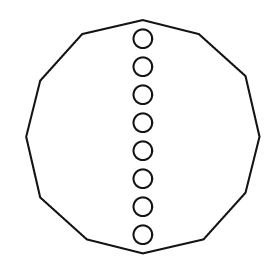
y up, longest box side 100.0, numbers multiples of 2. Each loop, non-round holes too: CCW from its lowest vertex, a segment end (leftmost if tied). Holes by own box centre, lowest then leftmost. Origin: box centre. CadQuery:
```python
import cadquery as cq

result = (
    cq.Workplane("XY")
    .moveTo(0.0, -50.0)
    .lineTo(26.0, -44.0)
    .lineTo(44.0, -24.0)
    .lineTo(50.0, 0.0)
    .lineTo(44.0, 26.0)
    .lineTo(24.0, 44.0)
    .lineTo(0.0, 50.0)
    .lineTo(-26.0, 44.0)
    .lineTo(-44.0, 24.0)
    .lineTo(-50.0, 0.0)
    .lineTo(-44.0, -26.0)
    .lineTo(-24.0, -44.0)
    .close()
    .moveTo(0.0, -42.0)
    .circle(4.0)
    .moveTo(0.0, -30.0)
    .circle(4.0)
    .moveTo(0.0, -18.0)
    .circle(4.0)
    .moveTo(0.0, -6.0)
    .circle(4.0)
    .moveTo(0.0, 6.0)
    .circle(4.0)
    .moveTo(0.0, 18.0)
    .circle(4.0)
    .moveTo(0.0, 30.0)
    .circle(4.0)
    .moveTo(0.0, 42.0)
    .circle(4.0)
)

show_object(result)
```